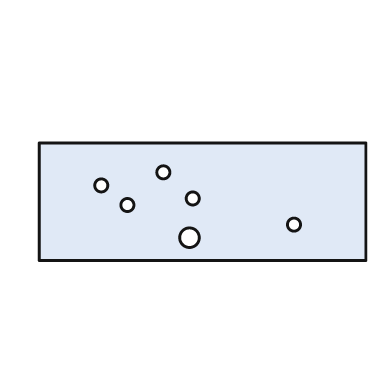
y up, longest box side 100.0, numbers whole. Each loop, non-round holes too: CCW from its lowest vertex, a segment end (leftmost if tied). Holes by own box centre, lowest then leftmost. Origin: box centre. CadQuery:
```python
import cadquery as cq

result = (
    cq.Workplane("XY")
    .moveTo(-50.0, -18.0)
    .lineTo(50.0, -18.0)
    .lineTo(50.0, 18.0)
    .lineTo(-50.0, 18.0)
    .close()
    .moveTo(-4.0, -11.0)
    .circle(3.0)
    .moveTo(28.0, -7.0)
    .circle(2.0)
    .moveTo(-23.0, -1.0)
    .circle(2.0)
    .moveTo(-3.0, 1.0)
    .circle(2.0)
    .moveTo(-31.0, 5.0)
    .circle(2.0)
    .moveTo(-12.0, 9.0)
    .circle(2.0)
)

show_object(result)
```